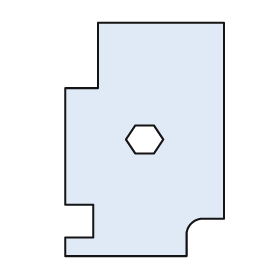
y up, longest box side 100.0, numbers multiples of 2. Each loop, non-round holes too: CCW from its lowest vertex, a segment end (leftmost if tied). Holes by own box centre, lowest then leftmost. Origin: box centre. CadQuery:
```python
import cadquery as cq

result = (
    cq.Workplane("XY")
    .moveTo(-34.0, -50.0)
    .lineTo(18.0, -50.0)
    .lineTo(18.0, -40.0)
    .threePointArc((20.0, -36.0), (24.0, -34.0))
    .lineTo(34.0, -34.0)
    .lineTo(34.0, 50.0)
    .lineTo(-20.0, 50.0)
    .lineTo(-20.0, 22.0)
    .lineTo(-34.0, 22.0)
    .lineTo(-34.0, -28.0)
    .lineTo(-22.0, -28.0)
    .lineTo(-22.0, -42.0)
    .lineTo(-34.0, -42.0)
    .close()
    .moveTo(-4.0, -6.0)
    .lineTo(4.0, -6.0)
    .lineTo(8.0, 0.0)
    .lineTo(4.0, 6.0)
    .lineTo(-4.0, 6.0)
    .lineTo(-8.0, 0.0)
    .close()
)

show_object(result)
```